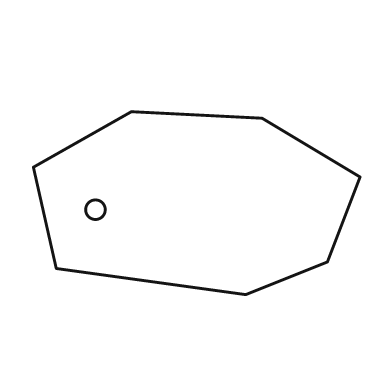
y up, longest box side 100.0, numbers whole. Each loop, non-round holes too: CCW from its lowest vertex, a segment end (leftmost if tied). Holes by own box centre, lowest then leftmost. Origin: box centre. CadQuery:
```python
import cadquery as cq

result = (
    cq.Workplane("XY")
    .moveTo(15.0, -28.0)
    .lineTo(40.0, -18.0)
    .lineTo(50.0, 8.0)
    .lineTo(20.0, 26.0)
    .lineTo(-20.0, 28.0)
    .lineTo(-50.0, 11.0)
    .lineTo(-43.0, -20.0)
    .close()
    .moveTo(-31.0, -2.0)
    .circle(3.0)
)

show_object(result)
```